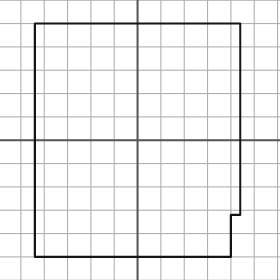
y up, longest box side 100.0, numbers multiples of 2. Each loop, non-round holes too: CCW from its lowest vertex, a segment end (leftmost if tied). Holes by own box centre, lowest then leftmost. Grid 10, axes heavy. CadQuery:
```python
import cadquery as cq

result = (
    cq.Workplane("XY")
    .moveTo(-44.0, -50.0)
    .lineTo(40.0, -50.0)
    .lineTo(40.0, -32.0)
    .lineTo(44.0, -32.0)
    .lineTo(44.0, 50.0)
    .lineTo(-44.0, 50.0)
    .close()
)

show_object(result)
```